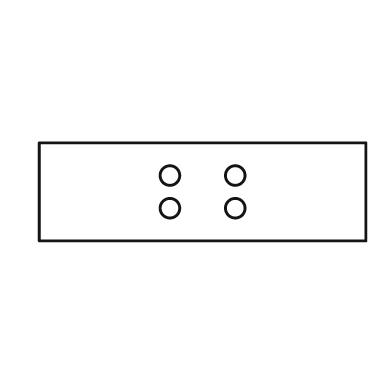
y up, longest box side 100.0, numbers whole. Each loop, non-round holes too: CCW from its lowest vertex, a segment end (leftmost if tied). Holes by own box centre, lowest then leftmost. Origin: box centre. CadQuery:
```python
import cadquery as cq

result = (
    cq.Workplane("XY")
    .moveTo(-50.0, -15.0)
    .lineTo(50.0, -15.0)
    .lineTo(50.0, 15.0)
    .lineTo(-50.0, 15.0)
    .close()
    .moveTo(-10.0, -5.0)
    .circle(3.0)
    .moveTo(10.0, -5.0)
    .circle(3.0)
    .moveTo(-10.0, 5.0)
    .circle(3.0)
    .moveTo(10.0, 5.0)
    .circle(3.0)
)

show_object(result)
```